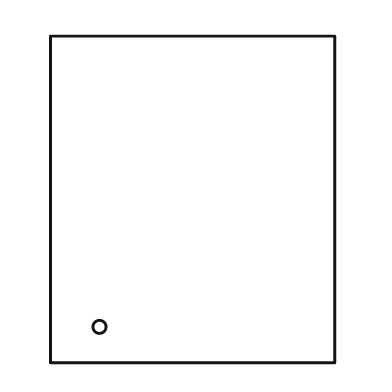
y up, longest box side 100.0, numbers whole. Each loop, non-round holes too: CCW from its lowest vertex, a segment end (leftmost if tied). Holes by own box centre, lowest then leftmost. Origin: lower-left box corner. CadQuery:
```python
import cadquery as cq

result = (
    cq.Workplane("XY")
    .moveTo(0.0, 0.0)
    .lineTo(87.0, 0.0)
    .lineTo(87.0, 100.0)
    .lineTo(0.0, 100.0)
    .close()
    .moveTo(15.0, 11.0)
    .circle(2.0)
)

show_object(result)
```